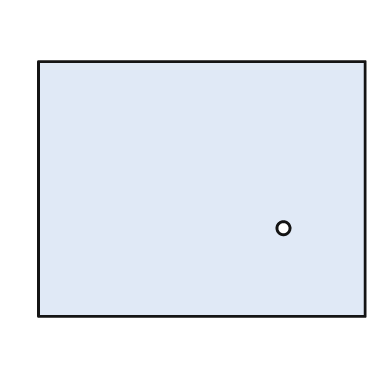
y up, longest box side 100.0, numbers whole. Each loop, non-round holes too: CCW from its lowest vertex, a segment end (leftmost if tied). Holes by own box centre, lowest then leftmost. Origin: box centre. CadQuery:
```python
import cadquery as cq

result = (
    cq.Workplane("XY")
    .moveTo(-50.0, -39.0)
    .lineTo(50.0, -39.0)
    .lineTo(50.0, 39.0)
    .lineTo(-50.0, 39.0)
    .close()
    .moveTo(25.0, -12.0)
    .circle(2.0)
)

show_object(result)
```